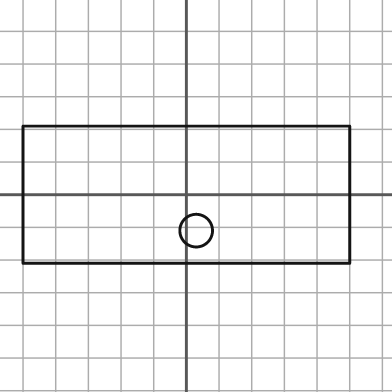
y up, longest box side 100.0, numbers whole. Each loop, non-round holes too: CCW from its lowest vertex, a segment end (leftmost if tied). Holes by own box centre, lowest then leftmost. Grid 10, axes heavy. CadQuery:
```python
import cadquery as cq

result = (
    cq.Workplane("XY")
    .moveTo(-50.0, -21.0)
    .lineTo(50.0, -21.0)
    .lineTo(50.0, 21.0)
    .lineTo(-50.0, 21.0)
    .close()
    .moveTo(3.0, -11.0)
    .circle(5.0)
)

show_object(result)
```